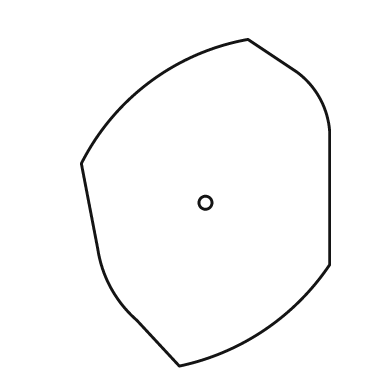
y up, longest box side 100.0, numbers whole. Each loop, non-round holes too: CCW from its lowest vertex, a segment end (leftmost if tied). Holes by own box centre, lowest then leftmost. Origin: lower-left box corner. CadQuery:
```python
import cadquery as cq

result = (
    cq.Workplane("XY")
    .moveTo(30.0, 0.0)
    .threePointArc((56.0, 11.0), (76.0, 31.0))
    .lineTo(76.0, 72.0)
    .threePointArc((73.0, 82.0), (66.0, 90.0))
    .lineTo(51.0, 100.0)
    .threePointArc((21.0, 87.0), (0.0, 62.0))
    .lineTo(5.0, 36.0)
    .threePointArc((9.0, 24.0), (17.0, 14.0))
    .close()
    .moveTo(38.0, 50.0)
    .circle(2.0)
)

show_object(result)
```